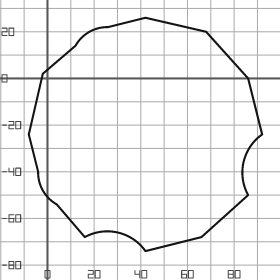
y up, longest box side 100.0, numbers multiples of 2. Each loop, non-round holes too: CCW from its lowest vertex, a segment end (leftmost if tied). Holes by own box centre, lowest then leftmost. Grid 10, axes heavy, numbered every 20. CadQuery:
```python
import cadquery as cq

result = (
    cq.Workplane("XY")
    .moveTo(42.0, -74.0)
    .lineTo(66.0, -68.0)
    .lineTo(86.0, -50.0)
    .threePointArc((84.0, -36.0), (92.0, -24.0))
    .lineTo(86.0, 0.0)
    .lineTo(68.0, 20.0)
    .lineTo(42.0, 26.0)
    .lineTo(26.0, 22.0)
    .threePointArc((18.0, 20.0), (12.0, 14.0))
    .lineTo(-2.0, 2.0)
    .lineTo(-8.0, -24.0)
    .lineTo(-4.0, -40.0)
    .threePointArc((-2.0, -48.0), (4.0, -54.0))
    .lineTo(16.0, -68.0)
    .threePointArc((30.0, -66.0), (42.0, -74.0))
    .close()
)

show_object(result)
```